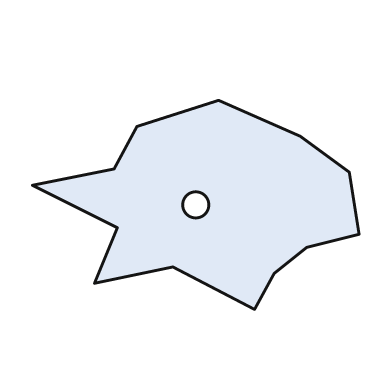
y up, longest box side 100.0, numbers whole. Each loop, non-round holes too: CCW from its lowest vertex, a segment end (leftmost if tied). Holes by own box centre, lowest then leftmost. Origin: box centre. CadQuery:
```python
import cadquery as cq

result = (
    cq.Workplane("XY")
    .moveTo(18.0, -32.0)
    .lineTo(24.0, -21.0)
    .lineTo(34.0, -13.0)
    .lineTo(50.0, -9.0)
    .lineTo(47.0, 10.0)
    .lineTo(32.0, 21.0)
    .lineTo(7.0, 32.0)
    .lineTo(-18.0, 24.0)
    .lineTo(-25.0, 11.0)
    .lineTo(-50.0, 6.0)
    .lineTo(-24.0, -7.0)
    .lineTo(-31.0, -24.0)
    .lineTo(-7.0, -19.0)
    .close()
    .moveTo(0.0, 0.0)
    .circle(4.0)
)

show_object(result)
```